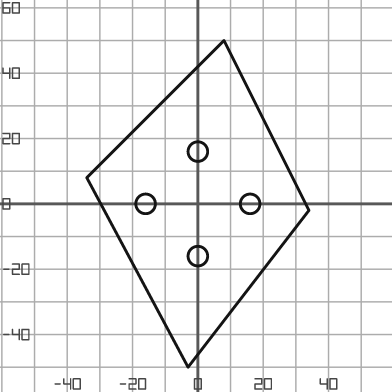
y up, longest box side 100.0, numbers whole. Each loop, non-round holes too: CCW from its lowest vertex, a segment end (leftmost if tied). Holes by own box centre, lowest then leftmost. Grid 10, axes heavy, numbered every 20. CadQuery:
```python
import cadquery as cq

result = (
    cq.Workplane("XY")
    .moveTo(-3.0, -50.0)
    .lineTo(34.0, -2.0)
    .lineTo(8.0, 50.0)
    .lineTo(-34.0, 8.0)
    .close()
    .moveTo(0.0, -16.0)
    .circle(3.0)
    .moveTo(-16.0, 0.0)
    .circle(3.0)
    .moveTo(16.0, 0.0)
    .circle(3.0)
    .moveTo(0.0, 16.0)
    .circle(3.0)
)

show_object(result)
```